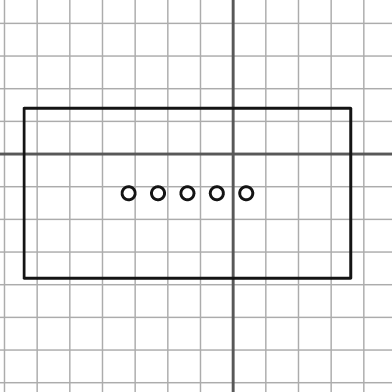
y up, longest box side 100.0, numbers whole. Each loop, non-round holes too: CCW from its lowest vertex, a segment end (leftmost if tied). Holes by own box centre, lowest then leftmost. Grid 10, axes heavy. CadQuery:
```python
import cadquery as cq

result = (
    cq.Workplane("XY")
    .moveTo(-64.0, -38.0)
    .lineTo(36.0, -38.0)
    .lineTo(36.0, 14.0)
    .lineTo(-64.0, 14.0)
    .close()
    .moveTo(-32.0, -12.0)
    .circle(2.0)
    .moveTo(-23.0, -12.0)
    .circle(2.0)
    .moveTo(-14.0, -12.0)
    .circle(2.0)
    .moveTo(-5.0, -12.0)
    .circle(2.0)
    .moveTo(4.0, -12.0)
    .circle(2.0)
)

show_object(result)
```